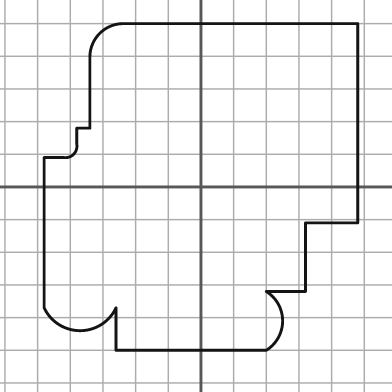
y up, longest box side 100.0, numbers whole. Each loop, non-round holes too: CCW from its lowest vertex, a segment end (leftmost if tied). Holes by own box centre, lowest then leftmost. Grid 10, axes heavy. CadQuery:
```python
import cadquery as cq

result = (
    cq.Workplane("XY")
    .moveTo(-26.0, -50.0)
    .lineTo(20.0, -50.0)
    .threePointArc((25.0, -41.0), (20.0, -32.0))
    .lineTo(32.0, -32.0)
    .lineTo(32.0, -11.0)
    .lineTo(48.0, -11.0)
    .lineTo(48.0, 50.0)
    .lineTo(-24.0, 50.0)
    .threePointArc((-31.0, 47.0), (-34.0, 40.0))
    .lineTo(-34.0, 18.0)
    .lineTo(-38.0, 18.0)
    .lineTo(-38.0, 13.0)
    .threePointArc((-39.0, 10.0), (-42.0, 9.0))
    .lineTo(-48.0, 9.0)
    .lineTo(-48.0, -37.0)
    .threePointArc((-37.0, -44.0), (-26.0, -37.0))
    .close()
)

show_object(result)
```